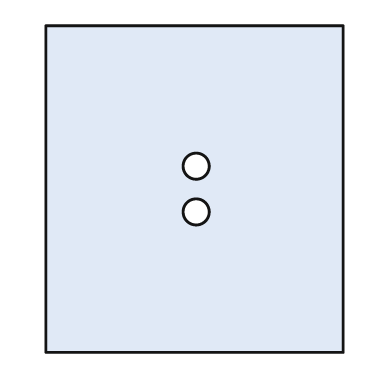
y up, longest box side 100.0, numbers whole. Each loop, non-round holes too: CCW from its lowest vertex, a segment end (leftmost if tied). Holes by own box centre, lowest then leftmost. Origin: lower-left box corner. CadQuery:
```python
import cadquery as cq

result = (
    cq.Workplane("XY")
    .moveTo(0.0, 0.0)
    .lineTo(91.0, 0.0)
    .lineTo(91.0, 100.0)
    .lineTo(0.0, 100.0)
    .close()
    .moveTo(46.0, 43.0)
    .circle(4.0)
    .moveTo(46.0, 57.0)
    .circle(4.0)
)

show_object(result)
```